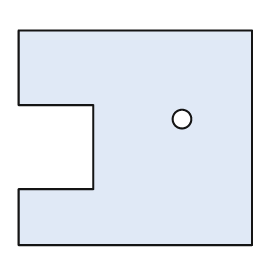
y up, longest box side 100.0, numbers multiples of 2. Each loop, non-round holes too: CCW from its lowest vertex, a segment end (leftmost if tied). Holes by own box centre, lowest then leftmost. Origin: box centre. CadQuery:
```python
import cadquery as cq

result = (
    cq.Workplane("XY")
    .moveTo(-50.0, -46.0)
    .lineTo(50.0, -46.0)
    .lineTo(50.0, 46.0)
    .lineTo(-50.0, 46.0)
    .lineTo(-50.0, 14.0)
    .lineTo(-18.0, 14.0)
    .lineTo(-18.0, -22.0)
    .lineTo(-50.0, -22.0)
    .close()
    .moveTo(20.0, 8.0)
    .circle(4.0)
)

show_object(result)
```